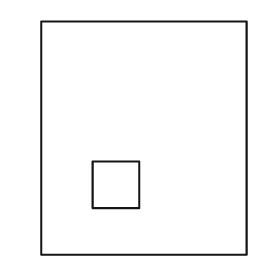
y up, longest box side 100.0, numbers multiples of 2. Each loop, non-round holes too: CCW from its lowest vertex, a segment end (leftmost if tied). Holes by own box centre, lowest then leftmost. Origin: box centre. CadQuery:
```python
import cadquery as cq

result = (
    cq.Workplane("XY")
    .moveTo(-44.0, -50.0)
    .lineTo(44.0, -50.0)
    .lineTo(44.0, 50.0)
    .lineTo(-44.0, 50.0)
    .close()
    .moveTo(-22.0, -30.0)
    .lineTo(-2.0, -30.0)
    .lineTo(-2.0, -10.0)
    .lineTo(-22.0, -10.0)
    .close()
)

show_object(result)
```